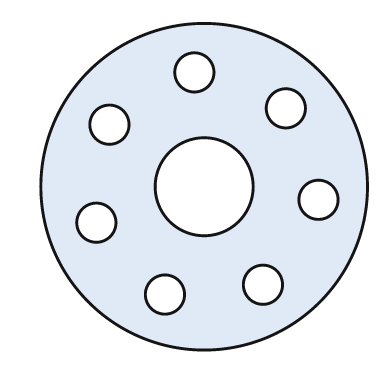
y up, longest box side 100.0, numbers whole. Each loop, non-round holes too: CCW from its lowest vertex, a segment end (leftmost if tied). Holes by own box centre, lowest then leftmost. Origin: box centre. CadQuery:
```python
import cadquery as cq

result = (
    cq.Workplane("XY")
    .moveTo(0.0, 0.0)
    .circle(50.0)
    .moveTo(-12.0, -33.0)
    .circle(6.0)
    .moveTo(18.0, -30.0)
    .circle(6.0)
    .moveTo(-33.0, -11.0)
    .circle(6.0)
    .moveTo(35.0, -4.0)
    .circle(6.0)
    .moveTo(0.0, 0.0)
    .circle(15.0)
    .moveTo(-29.0, 19.0)
    .circle(6.0)
    .moveTo(25.0, 24.0)
    .circle(6.0)
    .moveTo(-3.0, 35.0)
    .circle(6.0)
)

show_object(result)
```